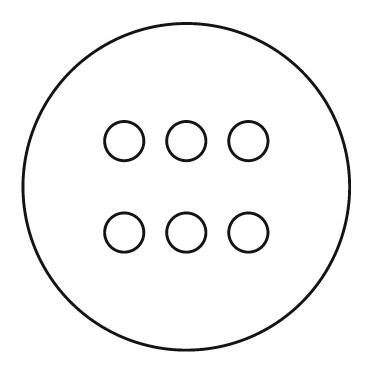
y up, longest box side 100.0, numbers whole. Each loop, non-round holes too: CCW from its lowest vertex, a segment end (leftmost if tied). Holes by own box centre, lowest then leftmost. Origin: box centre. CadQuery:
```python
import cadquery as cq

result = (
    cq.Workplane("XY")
    .moveTo(0.0, 0.0)
    .circle(50.0)
    .moveTo(-19.0, -14.0)
    .circle(6.0)
    .moveTo(0.0, -14.0)
    .circle(6.0)
    .moveTo(19.0, -14.0)
    .circle(6.0)
    .moveTo(-19.0, 14.0)
    .circle(6.0)
    .moveTo(0.0, 14.0)
    .circle(6.0)
    .moveTo(19.0, 14.0)
    .circle(6.0)
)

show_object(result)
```